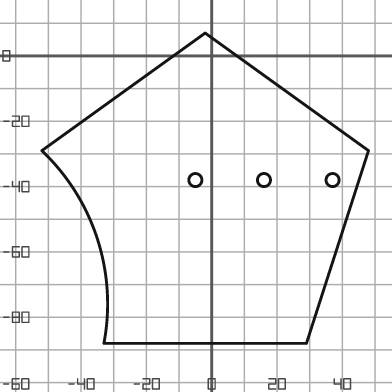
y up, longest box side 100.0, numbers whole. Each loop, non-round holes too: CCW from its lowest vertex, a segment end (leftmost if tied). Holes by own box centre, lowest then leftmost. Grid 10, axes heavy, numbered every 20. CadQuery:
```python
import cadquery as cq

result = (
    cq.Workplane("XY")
    .moveTo(-33.0, -88.0)
    .lineTo(29.0, -88.0)
    .lineTo(48.0, -29.0)
    .lineTo(-2.0, 7.0)
    .lineTo(-52.0, -29.0)
    .threePointArc((-35.0, -56.0), (-33.0, -88.0))
    .close()
    .moveTo(-5.0, -38.0)
    .circle(2.0)
    .moveTo(16.0, -38.0)
    .circle(2.0)
    .moveTo(37.0, -38.0)
    .circle(2.0)
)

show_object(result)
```